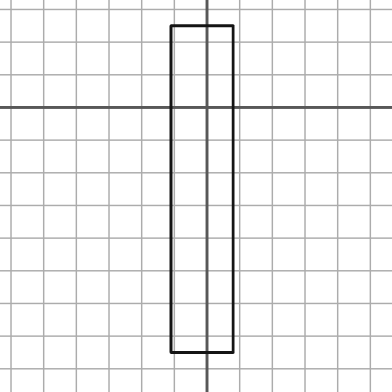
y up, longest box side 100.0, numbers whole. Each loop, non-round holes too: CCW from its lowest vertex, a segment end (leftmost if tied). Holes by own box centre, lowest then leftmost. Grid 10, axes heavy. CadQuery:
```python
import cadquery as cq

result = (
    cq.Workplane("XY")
    .moveTo(-11.0, -75.0)
    .lineTo(8.0, -75.0)
    .lineTo(8.0, 25.0)
    .lineTo(-11.0, 25.0)
    .close()
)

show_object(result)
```